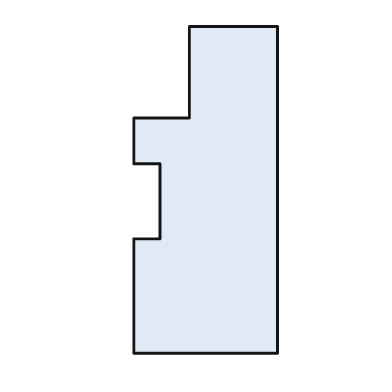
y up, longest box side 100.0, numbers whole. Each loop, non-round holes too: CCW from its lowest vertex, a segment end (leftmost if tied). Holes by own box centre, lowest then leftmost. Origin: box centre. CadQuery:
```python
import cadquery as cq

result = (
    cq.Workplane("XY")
    .moveTo(-22.0, -50.0)
    .lineTo(22.0, -50.0)
    .lineTo(22.0, 50.0)
    .lineTo(-5.0, 50.0)
    .lineTo(-5.0, 22.0)
    .lineTo(-22.0, 22.0)
    .lineTo(-22.0, 8.0)
    .lineTo(-14.0, 8.0)
    .lineTo(-14.0, -15.0)
    .lineTo(-22.0, -15.0)
    .close()
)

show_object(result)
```